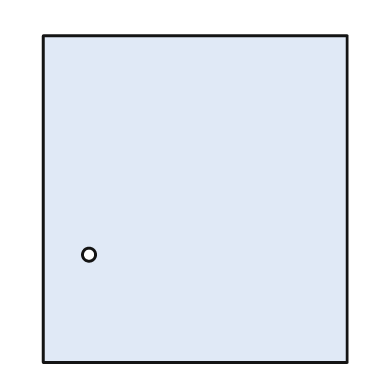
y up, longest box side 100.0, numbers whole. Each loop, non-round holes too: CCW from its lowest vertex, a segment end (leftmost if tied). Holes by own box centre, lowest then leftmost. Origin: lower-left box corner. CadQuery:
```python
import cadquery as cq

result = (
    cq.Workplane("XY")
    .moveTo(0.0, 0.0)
    .lineTo(93.0, 0.0)
    .lineTo(93.0, 100.0)
    .lineTo(0.0, 100.0)
    .close()
    .moveTo(14.0, 33.0)
    .circle(2.0)
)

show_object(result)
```